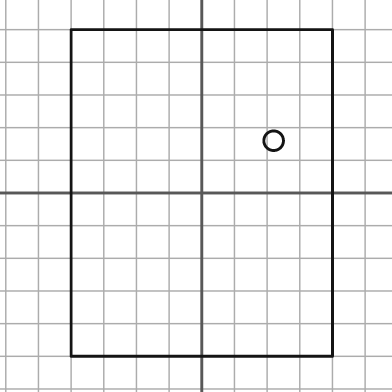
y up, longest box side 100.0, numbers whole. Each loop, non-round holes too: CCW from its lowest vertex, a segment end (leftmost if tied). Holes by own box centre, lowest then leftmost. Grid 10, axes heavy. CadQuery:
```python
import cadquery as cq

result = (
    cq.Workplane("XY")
    .moveTo(-40.0, -50.0)
    .lineTo(40.0, -50.0)
    .lineTo(40.0, 50.0)
    .lineTo(-40.0, 50.0)
    .close()
    .moveTo(22.0, 16.0)
    .circle(3.0)
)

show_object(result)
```